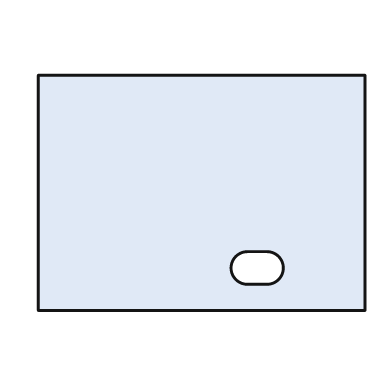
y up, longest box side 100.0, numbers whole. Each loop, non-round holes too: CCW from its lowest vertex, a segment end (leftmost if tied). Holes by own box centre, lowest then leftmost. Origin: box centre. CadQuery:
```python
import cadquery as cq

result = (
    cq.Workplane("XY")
    .moveTo(-50.0, -36.0)
    .lineTo(50.0, -36.0)
    .lineTo(50.0, 36.0)
    .lineTo(-50.0, 36.0)
    .close()
    .moveTo(14.0, -28.0)
    .lineTo(20.0, -28.0)
    .threePointArc((25.0, -23.0), (20.0, -18.0))
    .lineTo(14.0, -18.0)
    .threePointArc((9.0, -23.0), (14.0, -28.0))
    .close()
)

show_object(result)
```